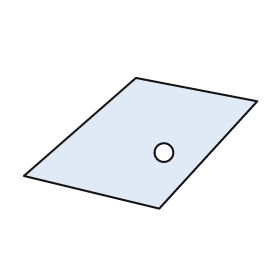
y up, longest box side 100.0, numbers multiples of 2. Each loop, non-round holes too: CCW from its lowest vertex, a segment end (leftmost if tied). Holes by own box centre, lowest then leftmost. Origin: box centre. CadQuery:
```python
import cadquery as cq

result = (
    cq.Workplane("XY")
    .moveTo(8.0, -28.0)
    .lineTo(50.0, 18.0)
    .lineTo(-2.0, 28.0)
    .lineTo(-50.0, -14.0)
    .close()
    .moveTo(10.0, -4.0)
    .circle(4.0)
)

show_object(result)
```